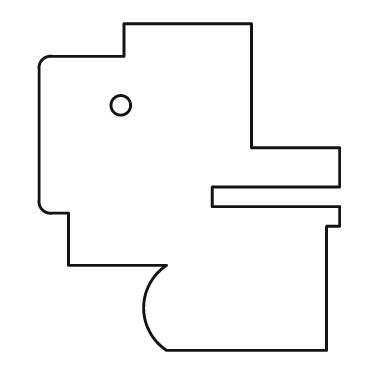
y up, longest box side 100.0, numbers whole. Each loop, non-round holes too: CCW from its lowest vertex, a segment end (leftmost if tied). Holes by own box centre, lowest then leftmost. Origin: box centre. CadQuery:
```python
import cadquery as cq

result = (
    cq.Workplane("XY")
    .moveTo(-7.0, -50.0)
    .lineTo(42.0, -50.0)
    .lineTo(42.0, -12.0)
    .lineTo(46.0, -12.0)
    .lineTo(46.0, -6.0)
    .lineTo(7.0, -6.0)
    .lineTo(7.0, 0.0)
    .lineTo(46.0, 0.0)
    .lineTo(46.0, 12.0)
    .lineTo(19.0, 12.0)
    .lineTo(19.0, 50.0)
    .lineTo(-20.0, 50.0)
    .lineTo(-20.0, 40.0)
    .lineTo(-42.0, 40.0)
    .threePointArc((-45.0, 39.0), (-46.0, 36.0))
    .lineTo(-46.0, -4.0)
    .threePointArc((-45.0, -7.0), (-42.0, -8.0))
    .lineTo(-37.0, -8.0)
    .lineTo(-37.0, -24.0)
    .lineTo(-7.0, -24.0)
    .threePointArc((-14.0, -37.0), (-7.0, -50.0))
    .close()
    .moveTo(-21.0, 25.0)
    .circle(3.0)
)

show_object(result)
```